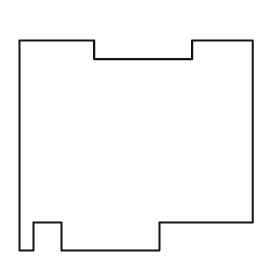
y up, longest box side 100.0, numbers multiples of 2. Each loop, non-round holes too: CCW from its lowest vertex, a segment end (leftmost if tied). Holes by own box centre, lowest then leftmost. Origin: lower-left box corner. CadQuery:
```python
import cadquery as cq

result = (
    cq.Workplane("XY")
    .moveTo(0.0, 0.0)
    .lineTo(6.0, 0.0)
    .lineTo(6.0, 12.0)
    .lineTo(18.0, 12.0)
    .lineTo(18.0, 0.0)
    .lineTo(60.0, 0.0)
    .lineTo(60.0, 12.0)
    .lineTo(100.0, 12.0)
    .lineTo(100.0, 90.0)
    .lineTo(74.0, 90.0)
    .lineTo(74.0, 82.0)
    .lineTo(32.0, 82.0)
    .lineTo(32.0, 90.0)
    .lineTo(0.0, 90.0)
    .close()
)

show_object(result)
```